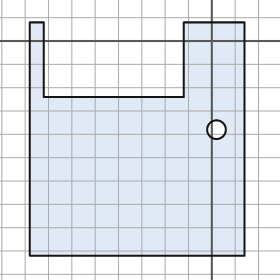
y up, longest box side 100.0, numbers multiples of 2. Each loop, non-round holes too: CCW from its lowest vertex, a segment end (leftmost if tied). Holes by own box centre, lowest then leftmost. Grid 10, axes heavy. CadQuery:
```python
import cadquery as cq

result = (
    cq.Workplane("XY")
    .moveTo(-78.0, -92.0)
    .lineTo(14.0, -92.0)
    .lineTo(14.0, 8.0)
    .lineTo(-12.0, 8.0)
    .lineTo(-12.0, -24.0)
    .lineTo(-72.0, -24.0)
    .lineTo(-72.0, 8.0)
    .lineTo(-78.0, 8.0)
    .close()
    .moveTo(2.0, -38.0)
    .circle(4.0)
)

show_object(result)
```